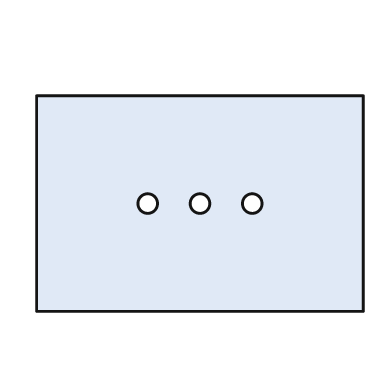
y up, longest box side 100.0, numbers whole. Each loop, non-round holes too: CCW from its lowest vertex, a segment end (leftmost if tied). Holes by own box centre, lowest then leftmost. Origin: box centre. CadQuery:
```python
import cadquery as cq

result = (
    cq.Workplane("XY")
    .moveTo(-50.0, -33.0)
    .lineTo(50.0, -33.0)
    .lineTo(50.0, 33.0)
    .lineTo(-50.0, 33.0)
    .close()
    .moveTo(-16.0, 0.0)
    .circle(3.0)
    .moveTo(0.0, 0.0)
    .circle(3.0)
    .moveTo(16.0, 0.0)
    .circle(3.0)
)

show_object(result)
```